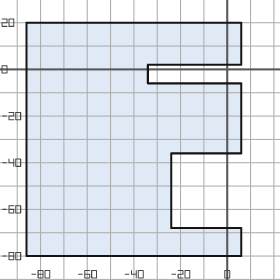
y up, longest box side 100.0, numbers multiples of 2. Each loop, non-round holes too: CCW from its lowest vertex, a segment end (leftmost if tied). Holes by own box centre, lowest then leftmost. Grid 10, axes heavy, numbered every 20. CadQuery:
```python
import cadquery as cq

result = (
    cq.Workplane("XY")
    .moveTo(-86.0, -80.0)
    .lineTo(6.0, -80.0)
    .lineTo(6.0, -68.0)
    .lineTo(-24.0, -68.0)
    .lineTo(-24.0, -36.0)
    .lineTo(6.0, -36.0)
    .lineTo(6.0, -6.0)
    .lineTo(-34.0, -6.0)
    .lineTo(-34.0, 2.0)
    .lineTo(6.0, 2.0)
    .lineTo(6.0, 20.0)
    .lineTo(-86.0, 20.0)
    .close()
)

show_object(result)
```